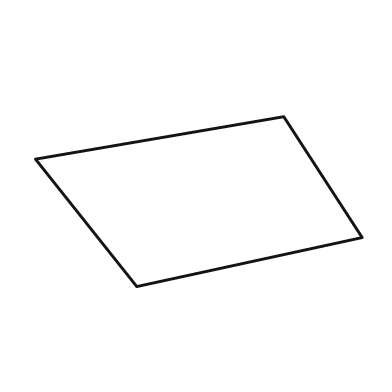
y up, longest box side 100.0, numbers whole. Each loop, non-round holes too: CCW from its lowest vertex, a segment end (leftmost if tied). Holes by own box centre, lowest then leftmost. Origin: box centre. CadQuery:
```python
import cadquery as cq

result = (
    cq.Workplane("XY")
    .moveTo(-19.0, -26.0)
    .lineTo(50.0, -11.0)
    .lineTo(26.0, 26.0)
    .lineTo(-50.0, 13.0)
    .close()
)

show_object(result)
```